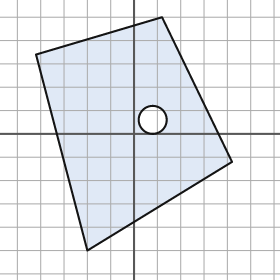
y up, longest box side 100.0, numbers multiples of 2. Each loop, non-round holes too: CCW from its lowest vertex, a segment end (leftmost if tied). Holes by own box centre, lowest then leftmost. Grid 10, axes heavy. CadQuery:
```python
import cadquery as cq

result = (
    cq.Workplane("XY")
    .moveTo(-20.0, -50.0)
    .lineTo(42.0, -12.0)
    .lineTo(12.0, 50.0)
    .lineTo(-42.0, 34.0)
    .close()
    .moveTo(8.0, 6.0)
    .circle(6.0)
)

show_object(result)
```